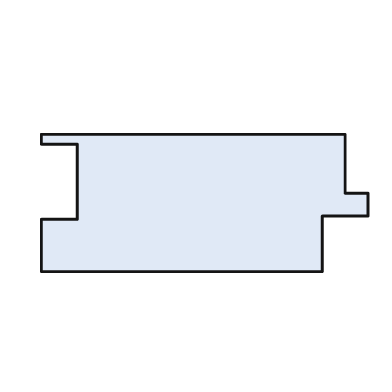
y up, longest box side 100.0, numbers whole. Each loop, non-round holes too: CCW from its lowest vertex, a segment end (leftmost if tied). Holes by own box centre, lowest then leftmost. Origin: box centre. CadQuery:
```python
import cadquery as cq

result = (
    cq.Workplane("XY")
    .moveTo(-50.0, -21.0)
    .lineTo(36.0, -21.0)
    .lineTo(36.0, -4.0)
    .lineTo(50.0, -4.0)
    .lineTo(50.0, 3.0)
    .lineTo(43.0, 3.0)
    .lineTo(43.0, 21.0)
    .lineTo(-50.0, 21.0)
    .lineTo(-50.0, 18.0)
    .lineTo(-39.0, 18.0)
    .lineTo(-39.0, -5.0)
    .lineTo(-50.0, -5.0)
    .close()
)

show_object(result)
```